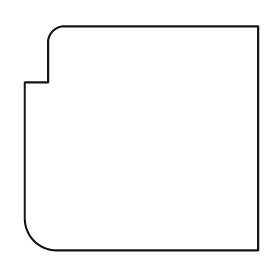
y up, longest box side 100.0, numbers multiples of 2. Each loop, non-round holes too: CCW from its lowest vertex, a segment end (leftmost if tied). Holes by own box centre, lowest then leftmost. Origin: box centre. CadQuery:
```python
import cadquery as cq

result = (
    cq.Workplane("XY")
    .moveTo(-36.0, -48.0)
    .lineTo(50.0, -48.0)
    .lineTo(50.0, 48.0)
    .lineTo(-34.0, 48.0)
    .threePointArc((-38.0, 46.0), (-40.0, 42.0))
    .lineTo(-40.0, 24.0)
    .lineTo(-50.0, 24.0)
    .lineTo(-50.0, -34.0)
    .threePointArc((-46.0, -44.0), (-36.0, -48.0))
    .close()
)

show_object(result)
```